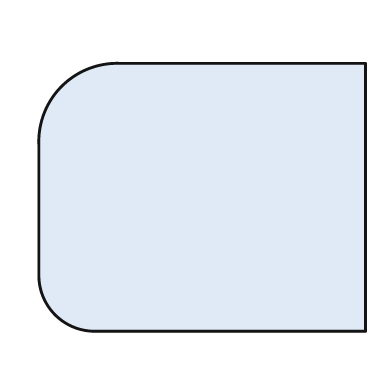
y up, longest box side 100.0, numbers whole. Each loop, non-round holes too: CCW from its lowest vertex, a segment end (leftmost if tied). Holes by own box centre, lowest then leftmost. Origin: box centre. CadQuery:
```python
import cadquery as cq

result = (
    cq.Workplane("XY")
    .moveTo(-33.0, -41.0)
    .lineTo(50.0, -41.0)
    .lineTo(50.0, 41.0)
    .lineTo(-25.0, 41.0)
    .threePointArc((-43.0, 34.0), (-50.0, 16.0))
    .lineTo(-50.0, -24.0)
    .threePointArc((-45.0, -36.0), (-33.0, -41.0))
    .close()
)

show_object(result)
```